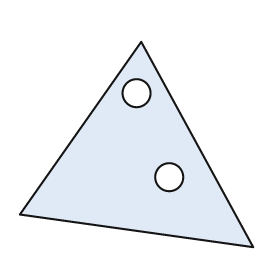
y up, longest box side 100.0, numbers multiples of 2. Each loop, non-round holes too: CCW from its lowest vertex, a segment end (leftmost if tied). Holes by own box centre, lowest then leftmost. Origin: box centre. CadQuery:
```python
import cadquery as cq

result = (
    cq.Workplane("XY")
    .moveTo(50.0, -44.0)
    .lineTo(2.0, 44.0)
    .lineTo(-50.0, -30.0)
    .close()
    .moveTo(14.0, -14.0)
    .circle(6.0)
    .moveTo(0.0, 22.0)
    .circle(6.0)
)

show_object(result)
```